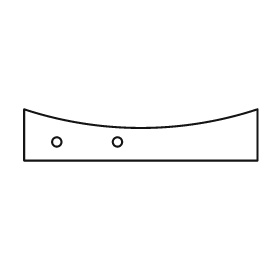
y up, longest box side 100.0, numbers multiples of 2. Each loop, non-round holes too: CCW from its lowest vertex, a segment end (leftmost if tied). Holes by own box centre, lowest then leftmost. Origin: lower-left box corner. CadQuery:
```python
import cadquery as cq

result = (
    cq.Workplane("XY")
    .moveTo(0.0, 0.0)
    .lineTo(100.0, 0.0)
    .lineTo(100.0, 22.0)
    .threePointArc((50.0, 14.0), (0.0, 22.0))
    .close()
    .moveTo(14.0, 8.0)
    .circle(2.0)
    .moveTo(40.0, 8.0)
    .circle(2.0)
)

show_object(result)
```